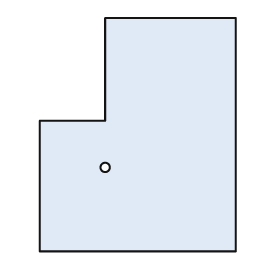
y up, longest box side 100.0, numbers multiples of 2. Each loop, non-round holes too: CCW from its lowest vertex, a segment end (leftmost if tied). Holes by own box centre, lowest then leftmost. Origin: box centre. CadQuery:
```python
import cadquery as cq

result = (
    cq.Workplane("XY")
    .moveTo(-42.0, -50.0)
    .lineTo(42.0, -50.0)
    .lineTo(42.0, 50.0)
    .lineTo(-14.0, 50.0)
    .lineTo(-14.0, 6.0)
    .lineTo(-42.0, 6.0)
    .close()
    .moveTo(-14.0, -14.0)
    .circle(2.0)
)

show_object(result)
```